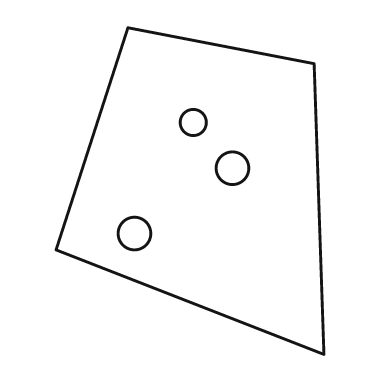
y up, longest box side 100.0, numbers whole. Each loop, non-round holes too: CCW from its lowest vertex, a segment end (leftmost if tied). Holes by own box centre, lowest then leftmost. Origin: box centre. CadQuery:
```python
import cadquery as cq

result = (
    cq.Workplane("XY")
    .moveTo(41.0, -50.0)
    .lineTo(38.0, 39.0)
    .lineTo(-19.0, 50.0)
    .lineTo(-41.0, -18.0)
    .close()
    .moveTo(-17.0, -13.0)
    .circle(5.0)
    .moveTo(13.0, 7.0)
    .circle(5.0)
    .moveTo(1.0, 21.0)
    .circle(4.0)
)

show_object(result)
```